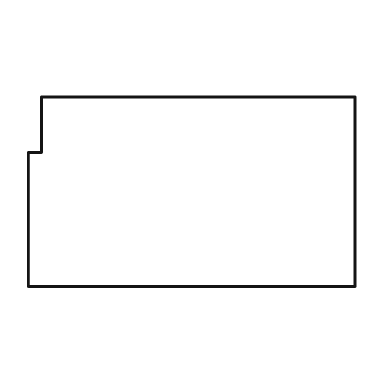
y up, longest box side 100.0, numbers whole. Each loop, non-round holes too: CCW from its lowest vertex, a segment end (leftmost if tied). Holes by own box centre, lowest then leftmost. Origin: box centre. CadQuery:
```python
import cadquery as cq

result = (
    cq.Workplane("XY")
    .moveTo(-50.0, -29.0)
    .lineTo(50.0, -29.0)
    .lineTo(50.0, 29.0)
    .lineTo(-46.0, 29.0)
    .lineTo(-46.0, 12.0)
    .lineTo(-50.0, 12.0)
    .close()
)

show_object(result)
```